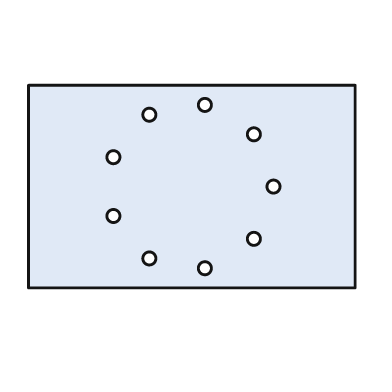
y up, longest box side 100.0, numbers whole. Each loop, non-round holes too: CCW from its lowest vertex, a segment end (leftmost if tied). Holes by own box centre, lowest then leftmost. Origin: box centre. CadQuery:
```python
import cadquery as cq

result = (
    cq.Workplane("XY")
    .moveTo(-50.0, -31.0)
    .lineTo(50.0, -31.0)
    .lineTo(50.0, 31.0)
    .lineTo(-50.0, 31.0)
    .close()
    .moveTo(4.0, -25.0)
    .circle(2.0)
    .moveTo(-13.0, -22.0)
    .circle(2.0)
    .moveTo(19.0, -16.0)
    .circle(2.0)
    .moveTo(-24.0, -9.0)
    .circle(2.0)
    .moveTo(25.0, 0.0)
    .circle(2.0)
    .moveTo(-24.0, 9.0)
    .circle(2.0)
    .moveTo(19.0, 16.0)
    .circle(2.0)
    .moveTo(-13.0, 22.0)
    .circle(2.0)
    .moveTo(4.0, 25.0)
    .circle(2.0)
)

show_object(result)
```